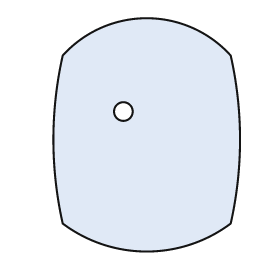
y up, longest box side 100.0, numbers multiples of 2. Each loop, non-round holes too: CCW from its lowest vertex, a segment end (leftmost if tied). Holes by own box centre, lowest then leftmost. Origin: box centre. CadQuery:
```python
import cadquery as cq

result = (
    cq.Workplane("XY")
    .moveTo(-36.0, -38.0)
    .threePointArc((0.0, -50.0), (36.0, -38.0))
    .threePointArc((40.0, -2.0), (36.0, 34.0))
    .threePointArc((0.0, 50.0), (-36.0, 34.0))
    .threePointArc((-40.0, -2.0), (-36.0, -38.0))
    .close()
    .moveTo(-10.0, 10.0)
    .circle(4.0)
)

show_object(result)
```